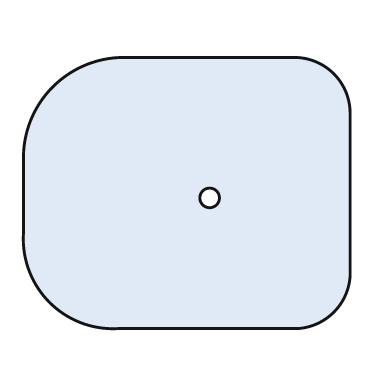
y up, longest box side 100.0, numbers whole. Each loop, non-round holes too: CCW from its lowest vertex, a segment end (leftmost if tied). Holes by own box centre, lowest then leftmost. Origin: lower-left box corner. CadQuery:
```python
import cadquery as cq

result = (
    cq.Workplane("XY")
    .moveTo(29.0, 0.0)
    .lineTo(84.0, 0.0)
    .threePointArc((95.0, 5.0), (100.0, 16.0))
    .lineTo(100.0, 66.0)
    .threePointArc((95.0, 78.0), (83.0, 83.0))
    .lineTo(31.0, 83.0)
    .threePointArc((9.0, 74.0), (0.0, 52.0))
    .lineTo(0.0, 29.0)
    .threePointArc((8.0, 8.0), (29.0, 0.0))
    .close()
    .moveTo(57.0, 40.0)
    .circle(3.0)
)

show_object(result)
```